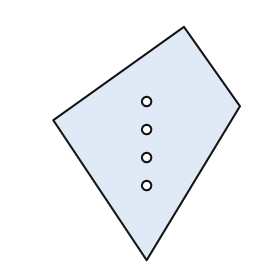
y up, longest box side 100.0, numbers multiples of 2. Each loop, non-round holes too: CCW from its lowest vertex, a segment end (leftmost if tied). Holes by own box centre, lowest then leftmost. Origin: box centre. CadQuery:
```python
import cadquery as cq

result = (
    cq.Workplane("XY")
    .moveTo(0.0, -50.0)
    .lineTo(40.0, 16.0)
    .lineTo(16.0, 50.0)
    .lineTo(-40.0, 10.0)
    .close()
    .moveTo(0.0, -18.0)
    .circle(2.0)
    .moveTo(0.0, -6.0)
    .circle(2.0)
    .moveTo(0.0, 6.0)
    .circle(2.0)
    .moveTo(0.0, 18.0)
    .circle(2.0)
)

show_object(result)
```